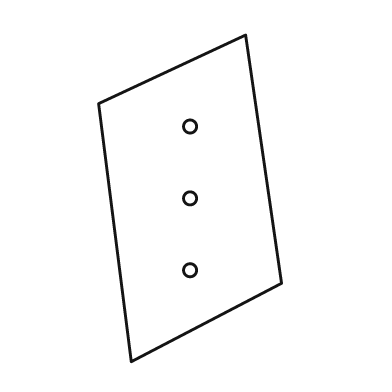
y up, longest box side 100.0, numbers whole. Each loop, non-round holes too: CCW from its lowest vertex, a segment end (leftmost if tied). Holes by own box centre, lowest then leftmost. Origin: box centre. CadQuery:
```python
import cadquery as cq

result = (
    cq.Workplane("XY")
    .moveTo(-18.0, -50.0)
    .lineTo(28.0, -26.0)
    .lineTo(17.0, 50.0)
    .lineTo(-28.0, 29.0)
    .close()
    .moveTo(0.0, -22.0)
    .circle(2.0)
    .moveTo(0.0, 0.0)
    .circle(2.0)
    .moveTo(0.0, 22.0)
    .circle(2.0)
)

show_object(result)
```